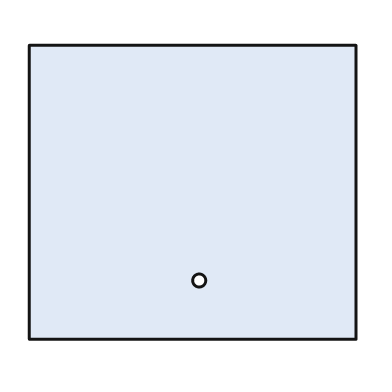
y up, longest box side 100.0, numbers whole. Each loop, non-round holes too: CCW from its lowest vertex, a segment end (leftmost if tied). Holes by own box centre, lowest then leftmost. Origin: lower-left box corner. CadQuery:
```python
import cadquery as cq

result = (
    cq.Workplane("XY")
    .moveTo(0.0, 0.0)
    .lineTo(100.0, 0.0)
    .lineTo(100.0, 90.0)
    .lineTo(0.0, 90.0)
    .close()
    .moveTo(52.0, 18.0)
    .circle(2.0)
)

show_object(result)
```